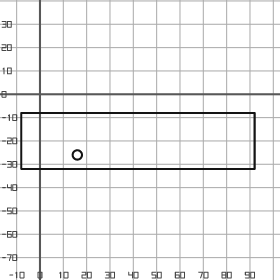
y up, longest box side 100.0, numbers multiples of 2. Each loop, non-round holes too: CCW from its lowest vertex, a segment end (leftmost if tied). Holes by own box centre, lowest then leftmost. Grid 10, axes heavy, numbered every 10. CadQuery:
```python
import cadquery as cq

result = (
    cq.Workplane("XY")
    .moveTo(-8.0, -32.0)
    .lineTo(92.0, -32.0)
    .lineTo(92.0, -8.0)
    .lineTo(-8.0, -8.0)
    .close()
    .moveTo(16.0, -26.0)
    .circle(2.0)
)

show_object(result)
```